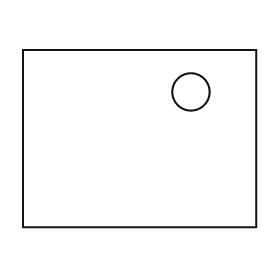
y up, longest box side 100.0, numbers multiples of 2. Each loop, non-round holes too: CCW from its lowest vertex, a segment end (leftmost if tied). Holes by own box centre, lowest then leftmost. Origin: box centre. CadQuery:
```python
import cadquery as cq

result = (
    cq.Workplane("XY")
    .moveTo(-50.0, -38.0)
    .lineTo(50.0, -38.0)
    .lineTo(50.0, 38.0)
    .lineTo(-50.0, 38.0)
    .close()
    .moveTo(22.0, 20.0)
    .circle(8.0)
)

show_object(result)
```